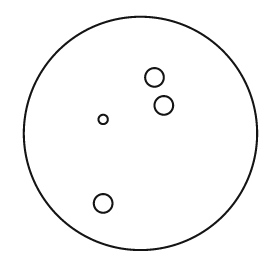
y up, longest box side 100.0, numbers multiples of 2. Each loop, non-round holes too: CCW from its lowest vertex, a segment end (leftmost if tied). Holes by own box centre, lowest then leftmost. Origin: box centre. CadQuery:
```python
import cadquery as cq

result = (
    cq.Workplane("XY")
    .moveTo(0.0, 0.0)
    .circle(50.0)
    .moveTo(-16.0, -30.0)
    .circle(4.0)
    .moveTo(-16.0, 6.0)
    .circle(2.0)
    .moveTo(10.0, 12.0)
    .circle(4.0)
    .moveTo(6.0, 24.0)
    .circle(4.0)
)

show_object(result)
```